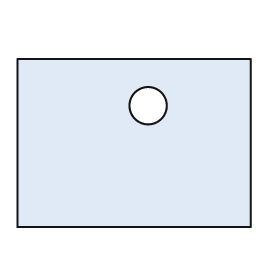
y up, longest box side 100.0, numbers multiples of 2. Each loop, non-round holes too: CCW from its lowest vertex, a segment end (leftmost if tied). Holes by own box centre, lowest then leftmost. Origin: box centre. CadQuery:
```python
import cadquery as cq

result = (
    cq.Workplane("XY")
    .moveTo(-50.0, -36.0)
    .lineTo(50.0, -36.0)
    .lineTo(50.0, 36.0)
    .lineTo(-50.0, 36.0)
    .close()
    .moveTo(6.0, 16.0)
    .circle(8.0)
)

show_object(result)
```